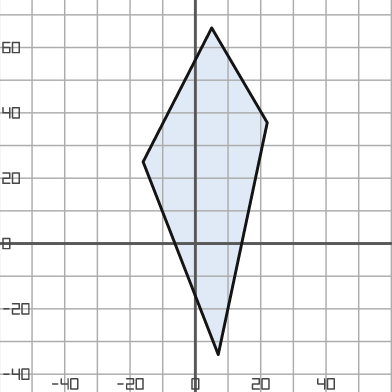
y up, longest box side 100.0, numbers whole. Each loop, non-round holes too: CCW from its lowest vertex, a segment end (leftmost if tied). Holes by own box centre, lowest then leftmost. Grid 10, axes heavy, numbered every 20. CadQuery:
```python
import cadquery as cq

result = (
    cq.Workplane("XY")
    .moveTo(7.0, -34.0)
    .lineTo(22.0, 37.0)
    .lineTo(5.0, 66.0)
    .lineTo(-16.0, 25.0)
    .close()
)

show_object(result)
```